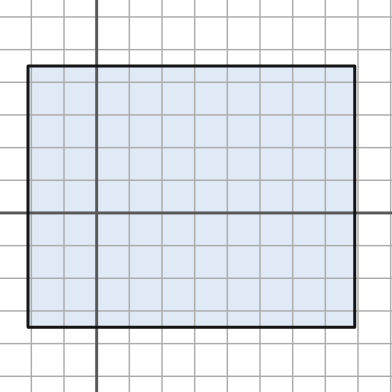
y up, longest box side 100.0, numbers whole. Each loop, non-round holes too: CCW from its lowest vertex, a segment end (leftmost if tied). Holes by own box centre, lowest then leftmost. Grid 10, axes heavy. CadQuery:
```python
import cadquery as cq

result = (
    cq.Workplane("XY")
    .moveTo(-21.0, -35.0)
    .lineTo(79.0, -35.0)
    .lineTo(79.0, 45.0)
    .lineTo(-21.0, 45.0)
    .close()
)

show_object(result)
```